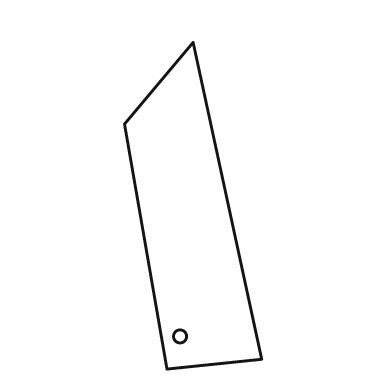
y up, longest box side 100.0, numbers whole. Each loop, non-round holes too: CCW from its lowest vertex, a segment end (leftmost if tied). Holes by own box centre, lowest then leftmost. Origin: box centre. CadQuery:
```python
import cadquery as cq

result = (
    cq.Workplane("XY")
    .moveTo(-8.0, -50.0)
    .lineTo(21.0, -47.0)
    .lineTo(0.0, 50.0)
    .lineTo(-21.0, 25.0)
    .close()
    .moveTo(-4.0, -40.0)
    .circle(2.0)
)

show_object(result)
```